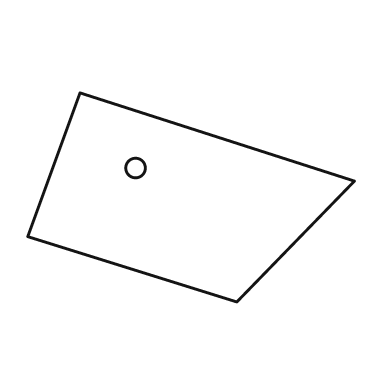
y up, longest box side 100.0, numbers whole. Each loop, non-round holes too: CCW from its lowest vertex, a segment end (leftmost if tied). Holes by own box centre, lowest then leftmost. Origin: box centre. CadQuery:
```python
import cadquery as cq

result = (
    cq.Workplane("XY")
    .moveTo(14.0, -32.0)
    .lineTo(50.0, 5.0)
    .lineTo(-34.0, 32.0)
    .lineTo(-50.0, -12.0)
    .close()
    .moveTo(-17.0, 9.0)
    .circle(3.0)
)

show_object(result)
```